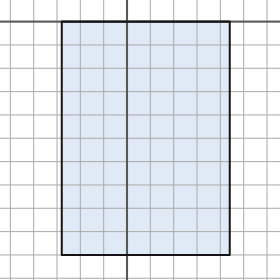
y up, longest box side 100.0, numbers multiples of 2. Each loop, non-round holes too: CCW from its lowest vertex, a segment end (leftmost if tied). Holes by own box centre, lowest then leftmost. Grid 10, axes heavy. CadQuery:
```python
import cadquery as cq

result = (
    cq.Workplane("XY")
    .moveTo(-28.0, -100.0)
    .lineTo(44.0, -100.0)
    .lineTo(44.0, 0.0)
    .lineTo(-28.0, 0.0)
    .close()
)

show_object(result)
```